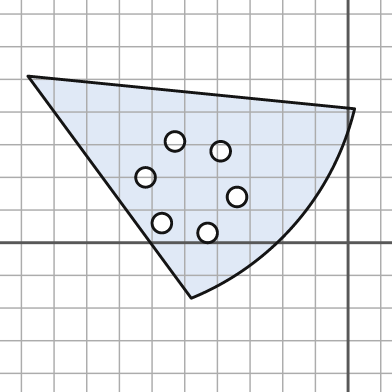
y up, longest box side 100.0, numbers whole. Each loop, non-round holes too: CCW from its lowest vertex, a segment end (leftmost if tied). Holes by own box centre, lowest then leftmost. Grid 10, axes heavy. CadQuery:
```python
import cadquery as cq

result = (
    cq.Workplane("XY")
    .moveTo(-48.0, -17.0)
    .threePointArc((-16.0, 6.0), (2.0, 41.0))
    .lineTo(-98.0, 51.0)
    .close()
    .moveTo(-43.0, 3.0)
    .circle(3.0)
    .moveTo(-57.0, 6.0)
    .circle(3.0)
    .moveTo(-34.0, 14.0)
    .circle(3.0)
    .moveTo(-62.0, 20.0)
    .circle(3.0)
    .moveTo(-39.0, 28.0)
    .circle(3.0)
    .moveTo(-53.0, 31.0)
    .circle(3.0)
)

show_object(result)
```